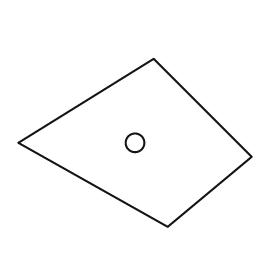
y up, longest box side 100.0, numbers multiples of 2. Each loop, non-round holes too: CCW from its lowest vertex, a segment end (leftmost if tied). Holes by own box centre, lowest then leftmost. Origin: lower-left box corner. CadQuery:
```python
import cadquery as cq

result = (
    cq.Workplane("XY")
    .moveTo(64.0, 0.0)
    .lineTo(100.0, 30.0)
    .lineTo(58.0, 72.0)
    .lineTo(0.0, 36.0)
    .close()
    .moveTo(50.0, 36.0)
    .circle(4.0)
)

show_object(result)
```